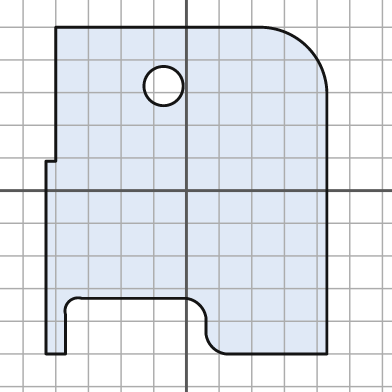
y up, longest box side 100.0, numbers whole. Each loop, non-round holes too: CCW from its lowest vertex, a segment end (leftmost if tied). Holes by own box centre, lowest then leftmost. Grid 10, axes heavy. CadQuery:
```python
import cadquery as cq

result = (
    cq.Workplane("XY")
    .moveTo(-43.0, -50.0)
    .lineTo(-37.0, -50.0)
    .lineTo(-37.0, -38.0)
    .threePointArc((-36.0, -34.0), (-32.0, -33.0))
    .lineTo(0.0, -33.0)
    .threePointArc((4.0, -35.0), (6.0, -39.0))
    .lineTo(6.0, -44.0)
    .threePointArc((8.0, -48.0), (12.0, -50.0))
    .lineTo(43.0, -50.0)
    .lineTo(43.0, 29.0)
    .threePointArc((37.0, 44.0), (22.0, 50.0))
    .lineTo(-40.0, 50.0)
    .lineTo(-40.0, 9.0)
    .lineTo(-43.0, 9.0)
    .close()
    .moveTo(-7.0, 32.0)
    .circle(6.0)
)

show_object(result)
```